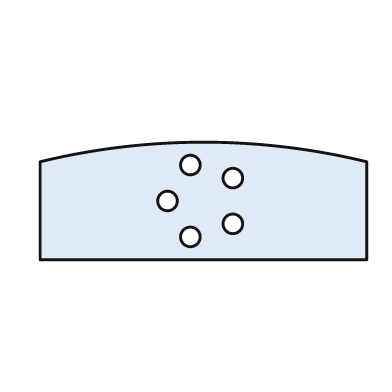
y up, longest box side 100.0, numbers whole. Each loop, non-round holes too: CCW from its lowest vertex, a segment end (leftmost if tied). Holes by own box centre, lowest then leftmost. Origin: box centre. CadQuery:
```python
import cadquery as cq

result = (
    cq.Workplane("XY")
    .moveTo(-50.0, -18.0)
    .lineTo(50.0, -18.0)
    .lineTo(50.0, 12.0)
    .threePointArc((0.0, 18.0), (-50.0, 12.0))
    .close()
    .moveTo(-4.0, -11.0)
    .circle(3.0)
    .moveTo(9.0, -7.0)
    .circle(3.0)
    .moveTo(-11.0, 0.0)
    .circle(3.0)
    .moveTo(9.0, 7.0)
    .circle(3.0)
    .moveTo(-4.0, 11.0)
    .circle(3.0)
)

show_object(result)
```